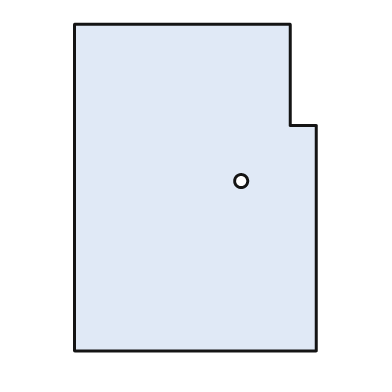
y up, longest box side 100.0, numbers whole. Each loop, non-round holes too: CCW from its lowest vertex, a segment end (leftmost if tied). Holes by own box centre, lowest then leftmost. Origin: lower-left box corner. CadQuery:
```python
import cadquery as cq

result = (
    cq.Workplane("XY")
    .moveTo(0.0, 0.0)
    .lineTo(74.0, 0.0)
    .lineTo(74.0, 69.0)
    .lineTo(66.0, 69.0)
    .lineTo(66.0, 100.0)
    .lineTo(0.0, 100.0)
    .close()
    .moveTo(51.0, 52.0)
    .circle(2.0)
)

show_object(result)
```